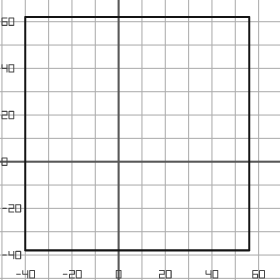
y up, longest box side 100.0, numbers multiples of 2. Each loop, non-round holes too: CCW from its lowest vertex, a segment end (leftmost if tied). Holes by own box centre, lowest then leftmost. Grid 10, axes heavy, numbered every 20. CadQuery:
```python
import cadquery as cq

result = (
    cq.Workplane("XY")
    .moveTo(-40.0, -38.0)
    .lineTo(56.0, -38.0)
    .lineTo(56.0, 62.0)
    .lineTo(-40.0, 62.0)
    .close()
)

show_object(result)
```